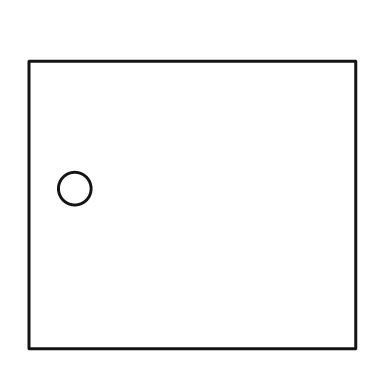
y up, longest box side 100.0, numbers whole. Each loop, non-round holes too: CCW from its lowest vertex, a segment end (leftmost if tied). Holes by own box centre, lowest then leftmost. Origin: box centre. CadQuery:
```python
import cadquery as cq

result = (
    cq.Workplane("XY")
    .moveTo(-50.0, -44.0)
    .lineTo(50.0, -44.0)
    .lineTo(50.0, 44.0)
    .lineTo(-50.0, 44.0)
    .close()
    .moveTo(-36.0, 5.0)
    .circle(5.0)
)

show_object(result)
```